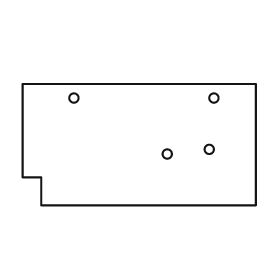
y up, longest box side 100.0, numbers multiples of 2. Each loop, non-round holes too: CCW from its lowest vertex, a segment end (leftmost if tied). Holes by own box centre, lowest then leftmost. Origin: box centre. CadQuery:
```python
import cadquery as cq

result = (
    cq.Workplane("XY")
    .moveTo(-42.0, -26.0)
    .lineTo(50.0, -26.0)
    .lineTo(50.0, 26.0)
    .lineTo(-50.0, 26.0)
    .lineTo(-50.0, -14.0)
    .lineTo(-42.0, -14.0)
    .close()
    .moveTo(12.0, -4.0)
    .circle(2.0)
    .moveTo(30.0, -2.0)
    .circle(2.0)
    .moveTo(-28.0, 20.0)
    .circle(2.0)
    .moveTo(32.0, 20.0)
    .circle(2.0)
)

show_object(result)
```